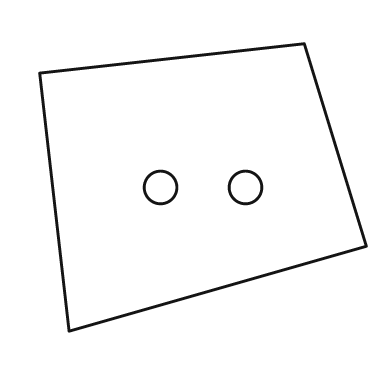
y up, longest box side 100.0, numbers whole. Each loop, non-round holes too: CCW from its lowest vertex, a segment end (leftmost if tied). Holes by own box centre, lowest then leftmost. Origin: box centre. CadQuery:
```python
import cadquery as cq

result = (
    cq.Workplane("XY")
    .moveTo(-41.0, -44.0)
    .lineTo(50.0, -18.0)
    .lineTo(31.0, 44.0)
    .lineTo(-50.0, 35.0)
    .close()
    .moveTo(-13.0, 0.0)
    .circle(5.0)
    .moveTo(13.0, 0.0)
    .circle(5.0)
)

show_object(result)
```